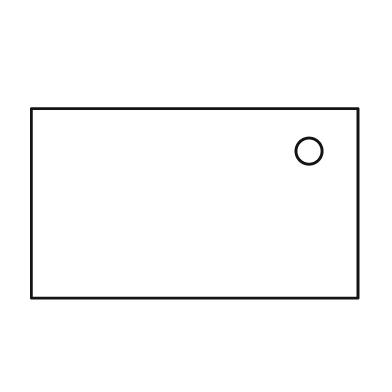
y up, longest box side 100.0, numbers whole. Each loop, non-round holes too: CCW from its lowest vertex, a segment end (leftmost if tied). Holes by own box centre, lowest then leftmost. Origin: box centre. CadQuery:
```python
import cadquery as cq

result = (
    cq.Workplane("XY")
    .moveTo(-50.0, -29.0)
    .lineTo(50.0, -29.0)
    .lineTo(50.0, 29.0)
    .lineTo(-50.0, 29.0)
    .close()
    .moveTo(35.0, 16.0)
    .circle(4.0)
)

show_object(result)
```